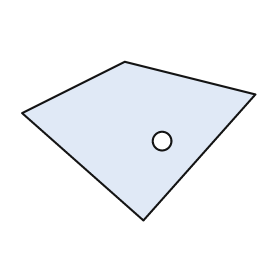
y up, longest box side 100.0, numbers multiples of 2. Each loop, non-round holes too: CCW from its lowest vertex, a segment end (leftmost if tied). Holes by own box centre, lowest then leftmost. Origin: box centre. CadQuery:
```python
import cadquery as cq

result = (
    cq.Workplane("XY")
    .moveTo(2.0, -34.0)
    .lineTo(50.0, 20.0)
    .lineTo(-6.0, 34.0)
    .lineTo(-50.0, 12.0)
    .close()
    .moveTo(10.0, 0.0)
    .circle(4.0)
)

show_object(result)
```